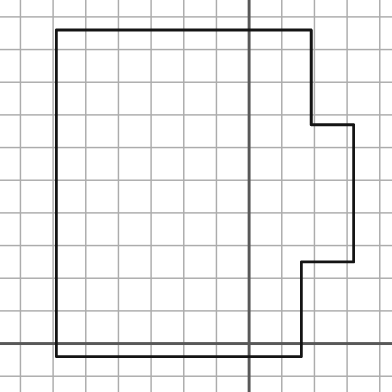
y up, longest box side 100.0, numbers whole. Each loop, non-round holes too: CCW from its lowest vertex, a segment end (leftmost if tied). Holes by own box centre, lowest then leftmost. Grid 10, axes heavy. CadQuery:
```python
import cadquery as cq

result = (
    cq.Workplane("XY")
    .moveTo(-59.0, -4.0)
    .lineTo(16.0, -4.0)
    .lineTo(16.0, 25.0)
    .lineTo(32.0, 25.0)
    .lineTo(32.0, 67.0)
    .lineTo(19.0, 67.0)
    .lineTo(19.0, 96.0)
    .lineTo(-59.0, 96.0)
    .close()
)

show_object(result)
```